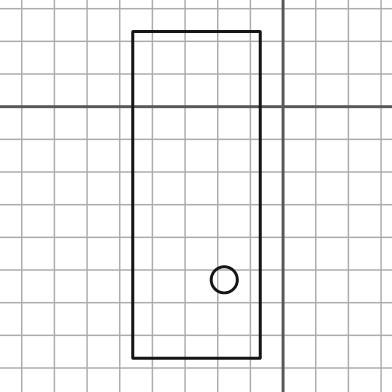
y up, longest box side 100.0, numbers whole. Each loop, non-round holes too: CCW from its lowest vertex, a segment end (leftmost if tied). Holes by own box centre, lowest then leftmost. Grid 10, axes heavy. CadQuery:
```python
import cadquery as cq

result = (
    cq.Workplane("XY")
    .moveTo(-46.0, -77.0)
    .lineTo(-7.0, -77.0)
    .lineTo(-7.0, 23.0)
    .lineTo(-46.0, 23.0)
    .close()
    .moveTo(-18.0, -53.0)
    .circle(4.0)
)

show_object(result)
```